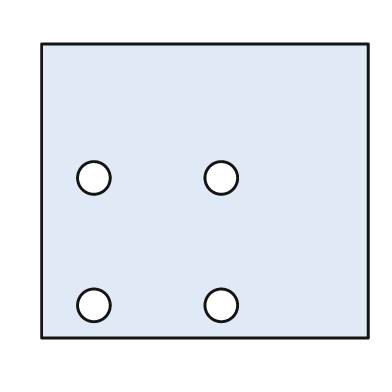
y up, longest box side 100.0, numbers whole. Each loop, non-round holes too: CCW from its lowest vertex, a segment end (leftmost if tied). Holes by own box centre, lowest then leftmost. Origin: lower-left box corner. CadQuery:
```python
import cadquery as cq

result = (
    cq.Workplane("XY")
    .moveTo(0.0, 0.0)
    .lineTo(100.0, 0.0)
    .lineTo(100.0, 90.0)
    .lineTo(0.0, 90.0)
    .close()
    .moveTo(16.0, 10.0)
    .circle(5.0)
    .moveTo(55.0, 10.0)
    .circle(5.0)
    .moveTo(16.0, 49.0)
    .circle(5.0)
    .moveTo(55.0, 49.0)
    .circle(5.0)
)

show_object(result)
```